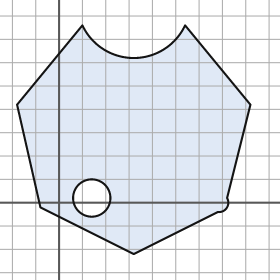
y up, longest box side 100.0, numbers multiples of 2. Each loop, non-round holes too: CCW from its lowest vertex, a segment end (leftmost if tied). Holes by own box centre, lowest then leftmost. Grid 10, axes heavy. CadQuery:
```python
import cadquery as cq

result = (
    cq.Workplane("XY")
    .moveTo(32.0, -22.0)
    .lineTo(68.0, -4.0)
    .threePointArc((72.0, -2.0), (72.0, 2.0))
    .lineTo(82.0, 42.0)
    .lineTo(54.0, 76.0)
    .threePointArc((32.0, 62.0), (10.0, 76.0))
    .lineTo(-18.0, 42.0)
    .lineTo(-8.0, -2.0)
    .close()
    .moveTo(14.0, 2.0)
    .circle(8.0)
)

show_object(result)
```